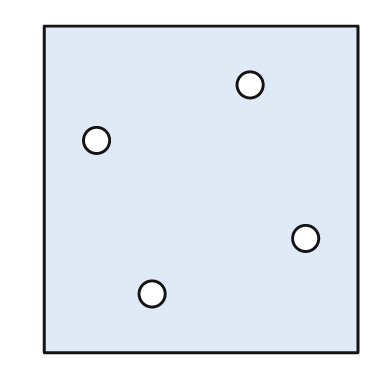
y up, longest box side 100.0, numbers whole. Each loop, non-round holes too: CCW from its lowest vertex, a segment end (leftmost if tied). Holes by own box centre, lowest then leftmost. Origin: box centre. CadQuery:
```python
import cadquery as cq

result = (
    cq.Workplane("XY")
    .moveTo(-48.0, -50.0)
    .lineTo(48.0, -50.0)
    .lineTo(48.0, 50.0)
    .lineTo(-48.0, 50.0)
    .close()
    .moveTo(-15.0, -32.0)
    .circle(4.0)
    .moveTo(32.0, -15.0)
    .circle(4.0)
    .moveTo(-32.0, 15.0)
    .circle(4.0)
    .moveTo(15.0, 32.0)
    .circle(4.0)
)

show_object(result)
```